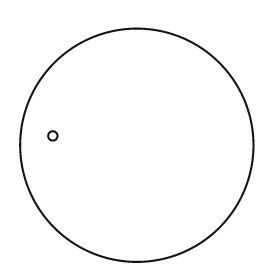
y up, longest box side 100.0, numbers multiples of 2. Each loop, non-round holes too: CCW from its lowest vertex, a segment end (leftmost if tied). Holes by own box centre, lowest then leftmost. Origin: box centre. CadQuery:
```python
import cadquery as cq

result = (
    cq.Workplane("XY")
    .moveTo(0.0, 0.0)
    .circle(50.0)
    .moveTo(-36.0, 4.0)
    .circle(2.0)
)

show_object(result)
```